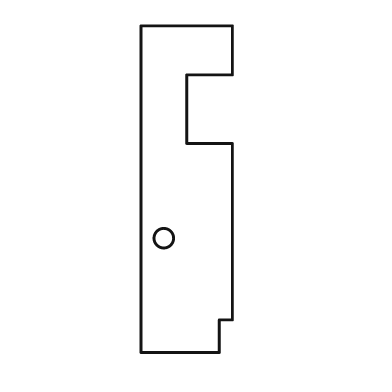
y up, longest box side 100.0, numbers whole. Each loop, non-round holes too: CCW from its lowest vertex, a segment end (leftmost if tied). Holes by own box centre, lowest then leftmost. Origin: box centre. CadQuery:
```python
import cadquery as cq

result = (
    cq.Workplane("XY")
    .moveTo(-14.0, -50.0)
    .lineTo(10.0, -50.0)
    .lineTo(10.0, -40.0)
    .lineTo(14.0, -40.0)
    .lineTo(14.0, 14.0)
    .lineTo(0.0, 14.0)
    .lineTo(0.0, 35.0)
    .lineTo(14.0, 35.0)
    .lineTo(14.0, 50.0)
    .lineTo(-14.0, 50.0)
    .close()
    .moveTo(-7.0, -15.0)
    .circle(3.0)
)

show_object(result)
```